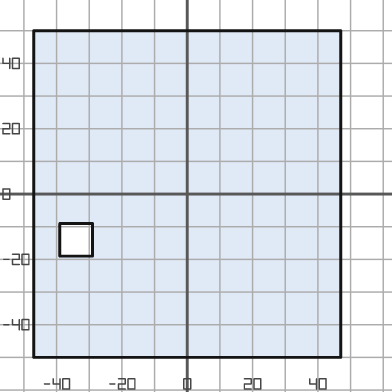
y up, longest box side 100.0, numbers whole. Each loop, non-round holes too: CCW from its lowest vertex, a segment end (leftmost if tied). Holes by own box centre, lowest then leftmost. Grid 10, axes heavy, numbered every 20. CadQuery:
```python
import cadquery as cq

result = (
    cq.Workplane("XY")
    .moveTo(-47.0, -50.0)
    .lineTo(47.0, -50.0)
    .lineTo(47.0, 50.0)
    .lineTo(-47.0, 50.0)
    .close()
    .moveTo(-39.0, -19.0)
    .lineTo(-29.0, -19.0)
    .lineTo(-29.0, -9.0)
    .lineTo(-39.0, -9.0)
    .close()
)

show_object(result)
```